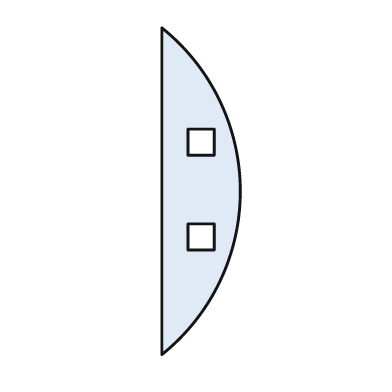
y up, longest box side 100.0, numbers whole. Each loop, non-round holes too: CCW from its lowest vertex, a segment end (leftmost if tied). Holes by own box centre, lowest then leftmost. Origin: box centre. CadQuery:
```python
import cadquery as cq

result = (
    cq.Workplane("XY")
    .moveTo(-12.0, -50.0)
    .threePointArc((12.0, 0.0), (-12.0, 50.0))
    .close()
    .moveTo(-4.0, -18.0)
    .lineTo(4.0, -18.0)
    .lineTo(4.0, -10.0)
    .lineTo(-4.0, -10.0)
    .close()
    .moveTo(-4.0, 11.0)
    .lineTo(4.0, 11.0)
    .lineTo(4.0, 19.0)
    .lineTo(-4.0, 19.0)
    .close()
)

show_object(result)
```